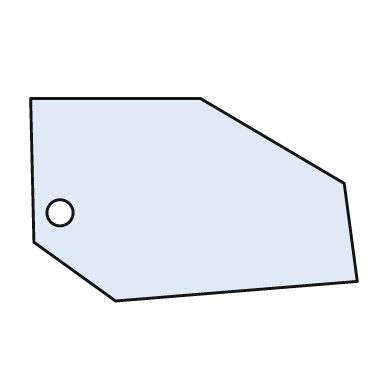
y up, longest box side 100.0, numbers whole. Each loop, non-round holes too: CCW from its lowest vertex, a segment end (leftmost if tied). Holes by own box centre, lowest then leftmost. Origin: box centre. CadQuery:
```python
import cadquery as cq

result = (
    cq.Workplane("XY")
    .moveTo(-24.0, -31.0)
    .lineTo(50.0, -25.0)
    .lineTo(46.0, 5.0)
    .lineTo(2.0, 31.0)
    .lineTo(-50.0, 31.0)
    .lineTo(-49.0, -13.0)
    .close()
    .moveTo(-41.0, -4.0)
    .circle(4.0)
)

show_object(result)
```